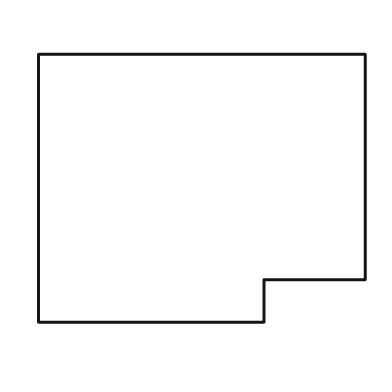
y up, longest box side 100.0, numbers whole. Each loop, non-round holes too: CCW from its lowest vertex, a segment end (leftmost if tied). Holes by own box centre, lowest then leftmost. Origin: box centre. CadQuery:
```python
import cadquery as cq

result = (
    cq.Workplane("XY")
    .moveTo(-50.0, -41.0)
    .lineTo(19.0, -41.0)
    .lineTo(19.0, -28.0)
    .lineTo(50.0, -28.0)
    .lineTo(50.0, 41.0)
    .lineTo(-50.0, 41.0)
    .close()
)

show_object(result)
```